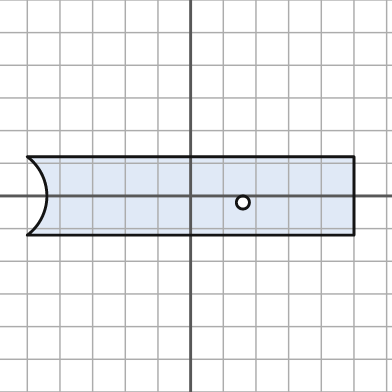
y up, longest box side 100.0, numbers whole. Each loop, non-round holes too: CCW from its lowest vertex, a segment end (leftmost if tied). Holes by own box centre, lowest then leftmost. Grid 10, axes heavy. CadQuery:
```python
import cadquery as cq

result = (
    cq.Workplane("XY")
    .moveTo(-50.0, -12.0)
    .lineTo(50.0, -12.0)
    .lineTo(50.0, 12.0)
    .lineTo(-50.0, 12.0)
    .threePointArc((-44.0, 0.0), (-50.0, -12.0))
    .close()
    .moveTo(16.0, -2.0)
    .circle(2.0)
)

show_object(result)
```